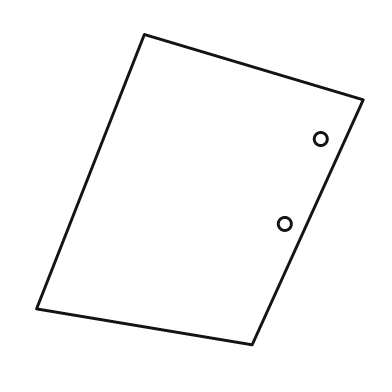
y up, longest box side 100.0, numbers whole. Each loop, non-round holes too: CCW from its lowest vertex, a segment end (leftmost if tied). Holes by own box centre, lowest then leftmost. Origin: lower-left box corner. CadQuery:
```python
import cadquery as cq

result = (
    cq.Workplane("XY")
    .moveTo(66.0, 0.0)
    .lineTo(100.0, 75.0)
    .lineTo(33.0, 95.0)
    .lineTo(0.0, 11.0)
    .close()
    .moveTo(76.0, 37.0)
    .circle(2.0)
    .moveTo(87.0, 63.0)
    .circle(2.0)
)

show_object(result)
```